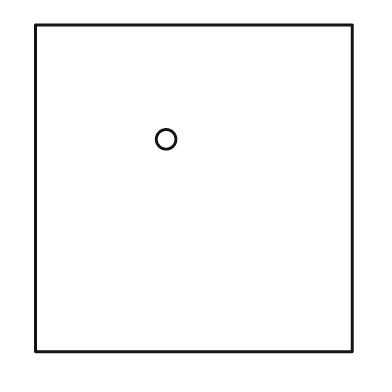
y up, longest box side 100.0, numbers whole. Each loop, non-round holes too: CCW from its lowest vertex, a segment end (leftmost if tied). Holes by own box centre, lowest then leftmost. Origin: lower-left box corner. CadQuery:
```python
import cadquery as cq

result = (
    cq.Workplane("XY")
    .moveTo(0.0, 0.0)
    .lineTo(97.0, 0.0)
    .lineTo(97.0, 100.0)
    .lineTo(0.0, 100.0)
    .close()
    .moveTo(40.0, 65.0)
    .circle(3.0)
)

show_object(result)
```